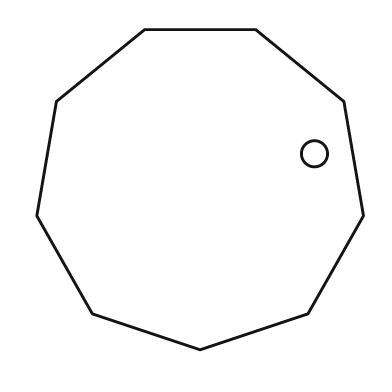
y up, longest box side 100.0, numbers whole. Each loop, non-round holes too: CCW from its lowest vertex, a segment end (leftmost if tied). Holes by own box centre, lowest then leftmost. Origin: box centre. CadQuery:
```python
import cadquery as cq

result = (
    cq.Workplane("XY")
    .moveTo(0.0, -49.0)
    .lineTo(33.0, -38.0)
    .lineTo(50.0, -8.0)
    .lineTo(44.0, 27.0)
    .lineTo(17.0, 49.0)
    .lineTo(-17.0, 49.0)
    .lineTo(-44.0, 27.0)
    .lineTo(-50.0, -8.0)
    .lineTo(-33.0, -38.0)
    .close()
    .moveTo(35.0, 11.0)
    .circle(4.0)
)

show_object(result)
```